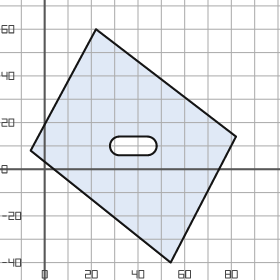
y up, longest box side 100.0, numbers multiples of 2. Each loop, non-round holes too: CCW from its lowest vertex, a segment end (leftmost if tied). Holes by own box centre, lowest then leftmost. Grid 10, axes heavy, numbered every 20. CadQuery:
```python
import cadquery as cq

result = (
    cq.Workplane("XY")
    .moveTo(54.0, -40.0)
    .lineTo(82.0, 14.0)
    .lineTo(22.0, 60.0)
    .lineTo(-6.0, 8.0)
    .close()
    .moveTo(32.0, 6.0)
    .lineTo(44.0, 6.0)
    .threePointArc((48.0, 10.0), (44.0, 14.0))
    .lineTo(32.0, 14.0)
    .threePointArc((28.0, 10.0), (32.0, 6.0))
    .close()
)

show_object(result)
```